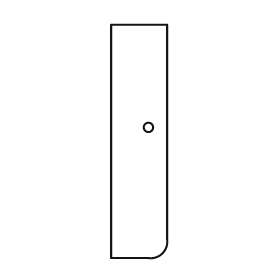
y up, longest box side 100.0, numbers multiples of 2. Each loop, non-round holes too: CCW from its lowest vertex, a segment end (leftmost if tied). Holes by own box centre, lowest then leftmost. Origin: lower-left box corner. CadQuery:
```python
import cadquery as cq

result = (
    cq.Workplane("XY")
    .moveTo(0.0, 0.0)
    .lineTo(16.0, 0.0)
    .threePointArc((22.0, 2.0), (24.0, 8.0))
    .lineTo(24.0, 100.0)
    .lineTo(0.0, 100.0)
    .close()
    .moveTo(16.0, 56.0)
    .circle(2.0)
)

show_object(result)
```